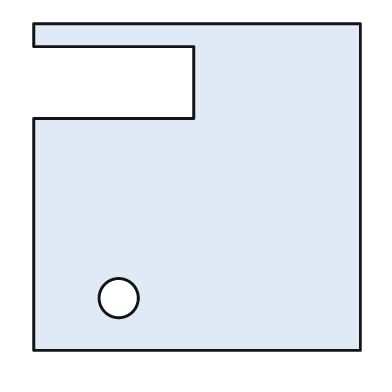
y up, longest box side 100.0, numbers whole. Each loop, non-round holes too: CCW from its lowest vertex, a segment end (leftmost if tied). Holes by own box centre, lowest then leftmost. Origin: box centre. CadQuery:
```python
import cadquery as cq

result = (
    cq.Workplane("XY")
    .moveTo(-50.0, -50.0)
    .lineTo(50.0, -50.0)
    .lineTo(50.0, 50.0)
    .lineTo(-50.0, 50.0)
    .lineTo(-50.0, 43.0)
    .lineTo(-1.0, 43.0)
    .lineTo(-1.0, 21.0)
    .lineTo(-50.0, 21.0)
    .close()
    .moveTo(-24.0, -34.0)
    .circle(6.0)
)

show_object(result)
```